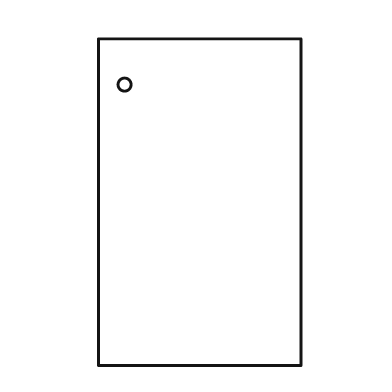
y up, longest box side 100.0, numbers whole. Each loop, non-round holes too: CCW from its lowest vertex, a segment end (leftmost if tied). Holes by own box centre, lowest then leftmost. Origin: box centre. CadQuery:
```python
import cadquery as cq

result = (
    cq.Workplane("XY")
    .moveTo(-31.0, -50.0)
    .lineTo(31.0, -50.0)
    .lineTo(31.0, 50.0)
    .lineTo(-31.0, 50.0)
    .close()
    .moveTo(-23.0, 36.0)
    .circle(2.0)
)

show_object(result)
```